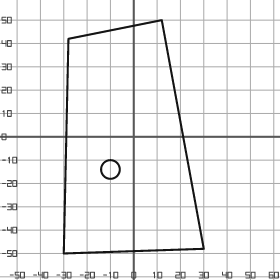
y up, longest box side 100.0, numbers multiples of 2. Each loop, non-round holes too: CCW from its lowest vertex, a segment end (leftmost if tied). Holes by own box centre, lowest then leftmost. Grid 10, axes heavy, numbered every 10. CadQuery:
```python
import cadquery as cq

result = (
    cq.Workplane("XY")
    .moveTo(-30.0, -50.0)
    .lineTo(30.0, -48.0)
    .lineTo(12.0, 50.0)
    .lineTo(-28.0, 42.0)
    .close()
    .moveTo(-10.0, -14.0)
    .circle(4.0)
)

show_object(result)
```